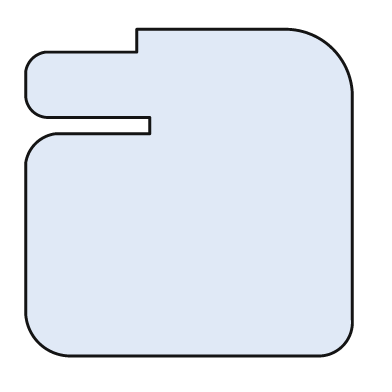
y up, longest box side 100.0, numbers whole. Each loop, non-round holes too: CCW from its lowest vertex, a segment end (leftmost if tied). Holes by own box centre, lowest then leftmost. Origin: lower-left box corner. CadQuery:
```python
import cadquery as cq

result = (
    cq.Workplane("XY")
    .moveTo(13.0, 0.0)
    .lineTo(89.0, 0.0)
    .threePointArc((97.0, 3.0), (100.0, 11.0))
    .lineTo(100.0, 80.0)
    .threePointArc((94.0, 94.0), (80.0, 100.0))
    .lineTo(34.0, 100.0)
    .lineTo(34.0, 93.0)
    .lineTo(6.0, 93.0)
    .threePointArc((2.0, 91.0), (0.0, 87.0))
    .lineTo(0.0, 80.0)
    .threePointArc((2.0, 75.0), (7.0, 73.0))
    .lineTo(38.0, 73.0)
    .lineTo(38.0, 68.0)
    .lineTo(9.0, 68.0)
    .threePointArc((3.0, 65.0), (0.0, 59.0))
    .lineTo(0.0, 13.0)
    .threePointArc((4.0, 4.0), (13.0, 0.0))
    .close()
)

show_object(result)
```